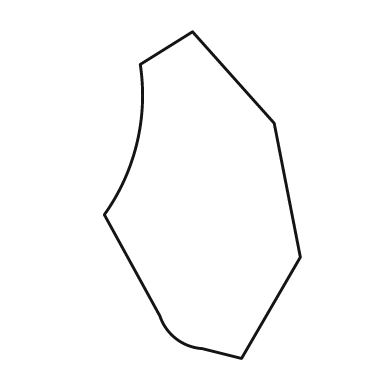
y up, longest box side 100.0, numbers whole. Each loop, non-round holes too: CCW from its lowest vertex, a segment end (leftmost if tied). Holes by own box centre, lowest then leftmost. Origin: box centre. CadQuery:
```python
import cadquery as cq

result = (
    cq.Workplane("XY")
    .moveTo(12.0, -50.0)
    .lineTo(30.0, -19.0)
    .lineTo(22.0, 22.0)
    .lineTo(-3.0, 50.0)
    .lineTo(-19.0, 40.0)
    .threePointArc((-20.0, 16.0), (-30.0, -6.0))
    .lineTo(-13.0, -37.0)
    .threePointArc((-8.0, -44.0), (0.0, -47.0))
    .close()
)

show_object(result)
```